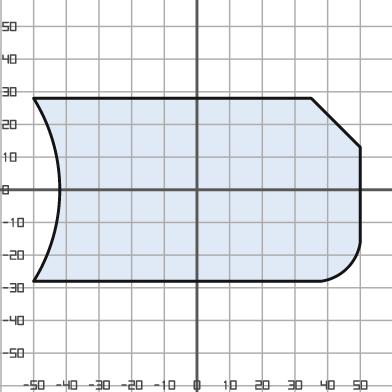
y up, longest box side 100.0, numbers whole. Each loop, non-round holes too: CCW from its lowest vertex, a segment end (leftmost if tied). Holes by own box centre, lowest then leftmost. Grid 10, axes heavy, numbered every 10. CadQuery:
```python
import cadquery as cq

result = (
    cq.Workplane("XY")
    .moveTo(-50.0, -28.0)
    .lineTo(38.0, -28.0)
    .threePointArc((46.0, -24.0), (50.0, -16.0))
    .lineTo(50.0, 13.0)
    .lineTo(35.0, 28.0)
    .lineTo(-50.0, 28.0)
    .threePointArc((-42.0, 0.0), (-50.0, -28.0))
    .close()
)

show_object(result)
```